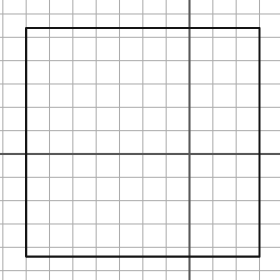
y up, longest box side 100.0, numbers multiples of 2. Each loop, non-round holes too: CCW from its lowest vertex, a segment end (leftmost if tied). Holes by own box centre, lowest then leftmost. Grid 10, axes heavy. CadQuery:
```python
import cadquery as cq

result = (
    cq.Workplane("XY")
    .moveTo(-70.0, -44.0)
    .lineTo(30.0, -44.0)
    .lineTo(30.0, 54.0)
    .lineTo(-70.0, 54.0)
    .close()
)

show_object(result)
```